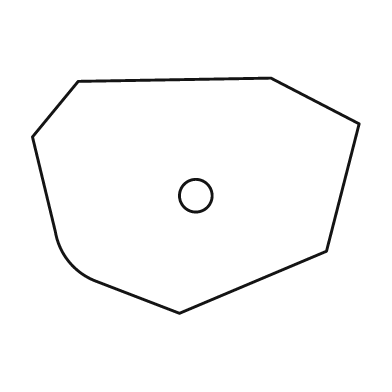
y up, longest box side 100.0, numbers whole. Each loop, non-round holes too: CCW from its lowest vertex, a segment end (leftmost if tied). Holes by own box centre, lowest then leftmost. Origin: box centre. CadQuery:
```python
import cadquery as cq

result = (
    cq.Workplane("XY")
    .moveTo(-5.0, -36.0)
    .lineTo(40.0, -17.0)
    .lineTo(50.0, 22.0)
    .lineTo(23.0, 36.0)
    .lineTo(-36.0, 35.0)
    .lineTo(-50.0, 18.0)
    .lineTo(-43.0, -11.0)
    .threePointArc((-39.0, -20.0), (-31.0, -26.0))
    .close()
    .moveTo(0.0, 0.0)
    .circle(5.0)
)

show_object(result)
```